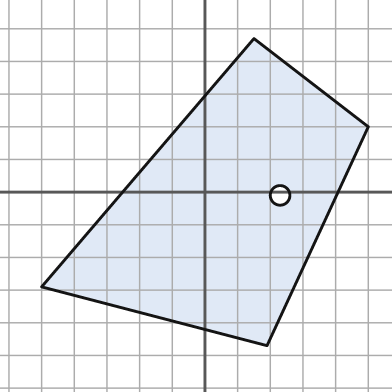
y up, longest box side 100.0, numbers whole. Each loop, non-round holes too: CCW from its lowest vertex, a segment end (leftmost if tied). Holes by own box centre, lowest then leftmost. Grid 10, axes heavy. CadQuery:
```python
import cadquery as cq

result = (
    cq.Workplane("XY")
    .moveTo(19.0, -47.0)
    .lineTo(50.0, 20.0)
    .lineTo(15.0, 47.0)
    .lineTo(-50.0, -29.0)
    .close()
    .moveTo(23.0, -1.0)
    .circle(3.0)
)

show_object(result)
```